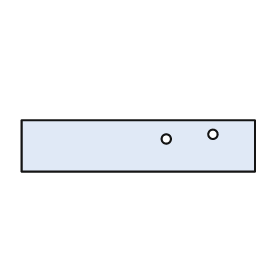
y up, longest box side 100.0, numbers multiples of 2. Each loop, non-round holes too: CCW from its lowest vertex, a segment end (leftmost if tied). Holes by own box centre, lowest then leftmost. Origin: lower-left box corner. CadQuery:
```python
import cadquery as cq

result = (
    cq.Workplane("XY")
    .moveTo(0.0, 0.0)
    .lineTo(100.0, 0.0)
    .lineTo(100.0, 22.0)
    .lineTo(0.0, 22.0)
    .close()
    .moveTo(62.0, 14.0)
    .circle(2.0)
    .moveTo(82.0, 16.0)
    .circle(2.0)
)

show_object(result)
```